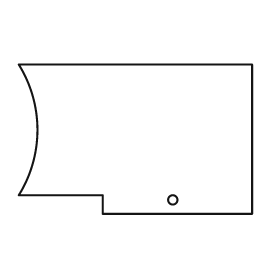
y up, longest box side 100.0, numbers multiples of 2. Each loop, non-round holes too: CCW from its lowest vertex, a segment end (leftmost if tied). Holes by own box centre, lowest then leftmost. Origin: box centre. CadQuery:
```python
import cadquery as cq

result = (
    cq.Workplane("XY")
    .moveTo(-14.0, -32.0)
    .lineTo(50.0, -32.0)
    .lineTo(50.0, 32.0)
    .lineTo(-50.0, 32.0)
    .threePointArc((-42.0, 4.0), (-50.0, -24.0))
    .lineTo(-14.0, -24.0)
    .close()
    .moveTo(16.0, -26.0)
    .circle(2.0)
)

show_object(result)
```